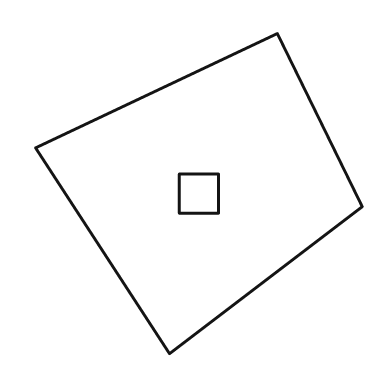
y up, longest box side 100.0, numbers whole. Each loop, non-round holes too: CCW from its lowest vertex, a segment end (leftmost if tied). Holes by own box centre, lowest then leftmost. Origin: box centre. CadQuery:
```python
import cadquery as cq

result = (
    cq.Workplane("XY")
    .moveTo(-9.0, -49.0)
    .lineTo(50.0, -4.0)
    .lineTo(24.0, 49.0)
    .lineTo(-50.0, 14.0)
    .close()
    .moveTo(-6.0, -6.0)
    .lineTo(6.0, -6.0)
    .lineTo(6.0, 6.0)
    .lineTo(-6.0, 6.0)
    .close()
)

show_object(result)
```